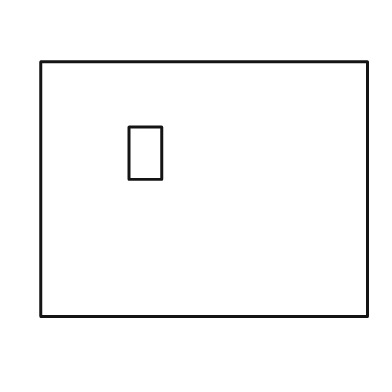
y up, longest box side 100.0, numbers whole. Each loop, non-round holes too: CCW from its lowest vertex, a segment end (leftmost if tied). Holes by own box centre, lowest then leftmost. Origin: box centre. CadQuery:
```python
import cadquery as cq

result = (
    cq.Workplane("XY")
    .moveTo(-50.0, -39.0)
    .lineTo(50.0, -39.0)
    .lineTo(50.0, 39.0)
    .lineTo(-50.0, 39.0)
    .close()
    .moveTo(-23.0, 3.0)
    .lineTo(-13.0, 3.0)
    .lineTo(-13.0, 19.0)
    .lineTo(-23.0, 19.0)
    .close()
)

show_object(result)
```